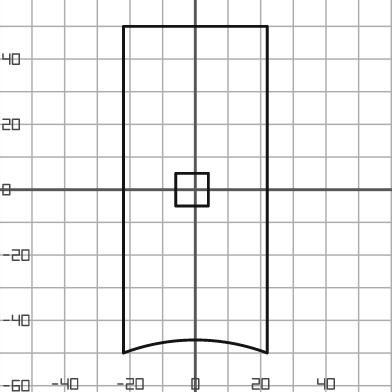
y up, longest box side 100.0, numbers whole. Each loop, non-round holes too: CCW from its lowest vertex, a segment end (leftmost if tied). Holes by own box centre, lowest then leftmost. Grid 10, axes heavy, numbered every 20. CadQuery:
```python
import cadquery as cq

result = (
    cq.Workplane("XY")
    .moveTo(-22.0, -50.0)
    .threePointArc((0.0, -46.0), (22.0, -50.0))
    .lineTo(22.0, 50.0)
    .lineTo(-22.0, 50.0)
    .close()
    .moveTo(-6.0, -5.0)
    .lineTo(4.0, -5.0)
    .lineTo(4.0, 5.0)
    .lineTo(-6.0, 5.0)
    .close()
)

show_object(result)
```